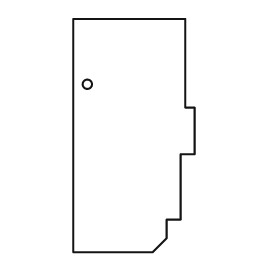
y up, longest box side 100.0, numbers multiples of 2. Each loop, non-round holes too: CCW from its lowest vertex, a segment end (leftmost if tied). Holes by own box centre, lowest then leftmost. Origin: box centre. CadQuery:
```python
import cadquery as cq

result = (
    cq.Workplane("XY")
    .moveTo(-26.0, -50.0)
    .lineTo(8.0, -50.0)
    .lineTo(14.0, -44.0)
    .lineTo(14.0, -36.0)
    .lineTo(20.0, -36.0)
    .lineTo(20.0, -8.0)
    .lineTo(26.0, -8.0)
    .lineTo(26.0, 12.0)
    .lineTo(22.0, 12.0)
    .lineTo(22.0, 50.0)
    .lineTo(-26.0, 50.0)
    .close()
    .moveTo(-20.0, 22.0)
    .circle(2.0)
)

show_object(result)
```